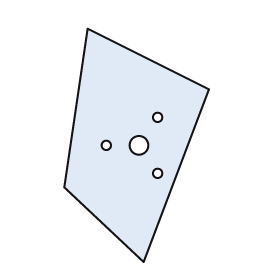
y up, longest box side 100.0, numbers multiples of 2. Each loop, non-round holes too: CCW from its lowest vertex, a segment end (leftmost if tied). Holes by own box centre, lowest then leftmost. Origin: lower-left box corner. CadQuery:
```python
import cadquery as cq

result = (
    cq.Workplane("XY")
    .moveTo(34.0, 0.0)
    .lineTo(62.0, 74.0)
    .lineTo(10.0, 100.0)
    .lineTo(0.0, 32.0)
    .close()
    .moveTo(40.0, 38.0)
    .circle(2.0)
    .moveTo(18.0, 50.0)
    .circle(2.0)
    .moveTo(32.0, 50.0)
    .circle(4.0)
    .moveTo(40.0, 62.0)
    .circle(2.0)
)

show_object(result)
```